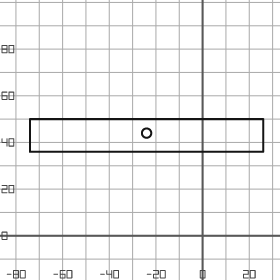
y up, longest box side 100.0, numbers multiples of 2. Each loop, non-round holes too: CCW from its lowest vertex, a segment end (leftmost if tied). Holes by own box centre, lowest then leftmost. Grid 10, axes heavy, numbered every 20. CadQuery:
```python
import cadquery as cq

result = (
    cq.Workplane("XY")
    .moveTo(-74.0, 36.0)
    .lineTo(26.0, 36.0)
    .lineTo(26.0, 50.0)
    .lineTo(-74.0, 50.0)
    .close()
    .moveTo(-24.0, 44.0)
    .circle(2.0)
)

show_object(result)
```